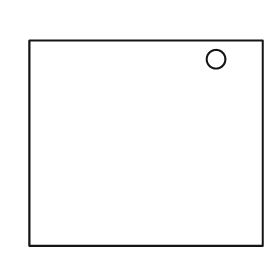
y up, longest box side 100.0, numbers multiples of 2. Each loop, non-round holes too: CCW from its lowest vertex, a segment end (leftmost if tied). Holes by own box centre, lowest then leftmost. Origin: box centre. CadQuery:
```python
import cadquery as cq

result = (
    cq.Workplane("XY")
    .moveTo(-50.0, -44.0)
    .lineTo(50.0, -44.0)
    .lineTo(50.0, 44.0)
    .lineTo(-50.0, 44.0)
    .close()
    .moveTo(30.0, 36.0)
    .circle(4.0)
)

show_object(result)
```